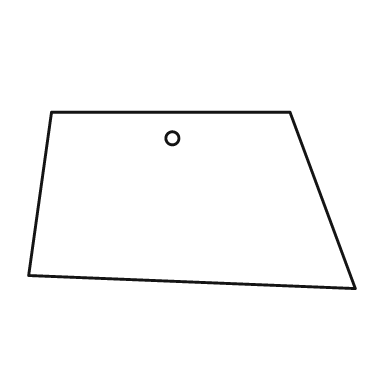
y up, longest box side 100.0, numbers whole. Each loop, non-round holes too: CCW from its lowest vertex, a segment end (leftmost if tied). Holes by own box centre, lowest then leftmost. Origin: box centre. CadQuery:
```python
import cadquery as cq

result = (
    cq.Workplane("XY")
    .moveTo(50.0, -27.0)
    .lineTo(30.0, 27.0)
    .lineTo(-43.0, 27.0)
    .lineTo(-50.0, -23.0)
    .close()
    .moveTo(-6.0, 19.0)
    .circle(2.0)
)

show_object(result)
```